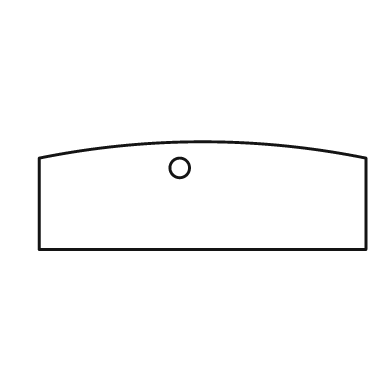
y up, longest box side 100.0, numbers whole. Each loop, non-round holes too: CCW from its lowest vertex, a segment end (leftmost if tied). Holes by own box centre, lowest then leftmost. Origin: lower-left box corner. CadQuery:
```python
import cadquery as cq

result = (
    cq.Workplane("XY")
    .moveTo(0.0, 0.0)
    .lineTo(100.0, 0.0)
    .lineTo(100.0, 28.0)
    .threePointArc((50.0, 33.0), (0.0, 28.0))
    .close()
    .moveTo(43.0, 25.0)
    .circle(3.0)
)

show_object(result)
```